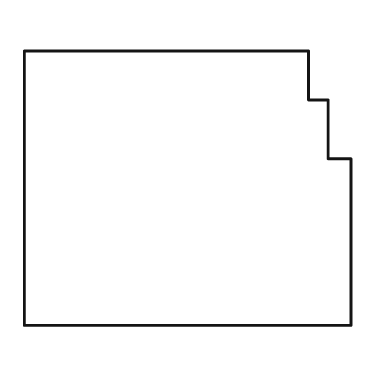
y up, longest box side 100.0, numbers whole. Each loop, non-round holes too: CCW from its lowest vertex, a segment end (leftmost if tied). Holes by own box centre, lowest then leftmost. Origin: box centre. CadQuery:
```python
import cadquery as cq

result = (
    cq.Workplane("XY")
    .moveTo(-50.0, -42.0)
    .lineTo(50.0, -42.0)
    .lineTo(50.0, 9.0)
    .lineTo(43.0, 9.0)
    .lineTo(43.0, 27.0)
    .lineTo(37.0, 27.0)
    .lineTo(37.0, 42.0)
    .lineTo(-50.0, 42.0)
    .close()
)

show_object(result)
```